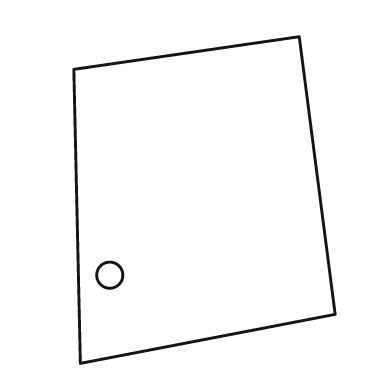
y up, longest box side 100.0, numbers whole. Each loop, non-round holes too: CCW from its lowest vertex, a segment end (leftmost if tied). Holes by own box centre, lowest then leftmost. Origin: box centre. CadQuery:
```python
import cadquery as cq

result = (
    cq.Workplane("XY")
    .moveTo(-38.0, -50.0)
    .lineTo(40.0, -35.0)
    .lineTo(29.0, 50.0)
    .lineTo(-40.0, 40.0)
    .close()
    .moveTo(-29.0, -23.0)
    .circle(4.0)
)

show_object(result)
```